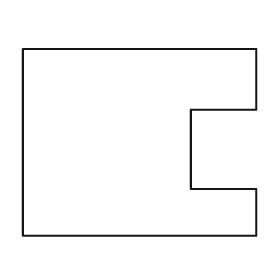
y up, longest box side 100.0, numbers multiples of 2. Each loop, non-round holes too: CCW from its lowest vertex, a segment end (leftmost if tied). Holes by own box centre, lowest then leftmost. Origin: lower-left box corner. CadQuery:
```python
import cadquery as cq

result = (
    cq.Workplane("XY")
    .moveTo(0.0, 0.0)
    .lineTo(100.0, 0.0)
    .lineTo(100.0, 20.0)
    .lineTo(72.0, 20.0)
    .lineTo(72.0, 54.0)
    .lineTo(100.0, 54.0)
    .lineTo(100.0, 80.0)
    .lineTo(0.0, 80.0)
    .close()
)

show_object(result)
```